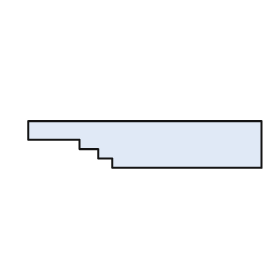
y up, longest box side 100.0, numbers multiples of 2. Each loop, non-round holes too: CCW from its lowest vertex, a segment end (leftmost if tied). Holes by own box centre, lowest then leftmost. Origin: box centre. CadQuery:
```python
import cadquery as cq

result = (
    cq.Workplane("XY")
    .moveTo(-14.0, -10.0)
    .lineTo(50.0, -10.0)
    .lineTo(50.0, 10.0)
    .lineTo(-50.0, 10.0)
    .lineTo(-50.0, 2.0)
    .lineTo(-28.0, 2.0)
    .lineTo(-28.0, -2.0)
    .lineTo(-20.0, -2.0)
    .lineTo(-20.0, -6.0)
    .lineTo(-14.0, -6.0)
    .close()
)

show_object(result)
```